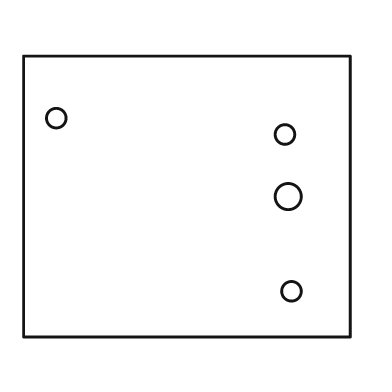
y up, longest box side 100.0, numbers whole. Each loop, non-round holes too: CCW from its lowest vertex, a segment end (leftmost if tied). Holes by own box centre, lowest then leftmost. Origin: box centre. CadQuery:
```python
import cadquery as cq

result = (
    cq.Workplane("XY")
    .moveTo(-50.0, -43.0)
    .lineTo(50.0, -43.0)
    .lineTo(50.0, 43.0)
    .lineTo(-50.0, 43.0)
    .close()
    .moveTo(32.0, -29.0)
    .circle(3.0)
    .moveTo(31.0, 0.0)
    .circle(4.0)
    .moveTo(30.0, 19.0)
    .circle(3.0)
    .moveTo(-40.0, 24.0)
    .circle(3.0)
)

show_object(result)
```